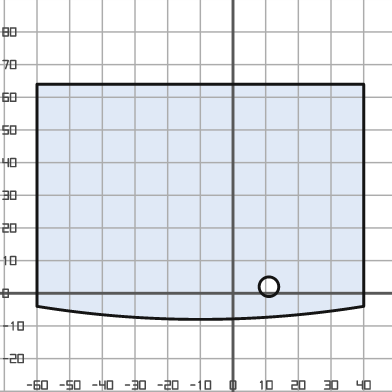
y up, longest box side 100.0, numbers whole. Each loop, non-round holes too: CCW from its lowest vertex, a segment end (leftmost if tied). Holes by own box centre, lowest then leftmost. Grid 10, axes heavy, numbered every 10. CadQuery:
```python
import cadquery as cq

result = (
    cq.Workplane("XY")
    .moveTo(-60.0, -4.0)
    .threePointArc((-10.0, -8.0), (40.0, -4.0))
    .lineTo(40.0, 64.0)
    .lineTo(-60.0, 64.0)
    .close()
    .moveTo(11.0, 2.0)
    .circle(3.0)
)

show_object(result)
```